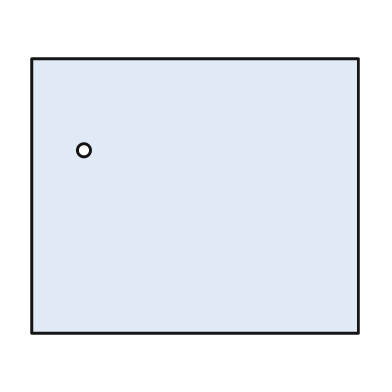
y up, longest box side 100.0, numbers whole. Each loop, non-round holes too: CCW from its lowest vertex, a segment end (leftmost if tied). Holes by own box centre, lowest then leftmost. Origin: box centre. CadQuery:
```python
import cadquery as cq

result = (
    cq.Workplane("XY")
    .moveTo(-50.0, -42.0)
    .lineTo(50.0, -42.0)
    .lineTo(50.0, 42.0)
    .lineTo(-50.0, 42.0)
    .close()
    .moveTo(-34.0, 14.0)
    .circle(2.0)
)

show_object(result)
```